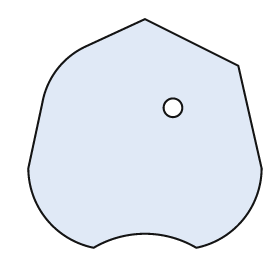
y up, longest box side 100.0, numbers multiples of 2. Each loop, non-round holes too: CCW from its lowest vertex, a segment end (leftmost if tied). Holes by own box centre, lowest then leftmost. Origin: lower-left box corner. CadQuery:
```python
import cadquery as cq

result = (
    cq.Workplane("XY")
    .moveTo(28.0, 0.0)
    .threePointArc((50.0, 6.0), (72.0, 0.0))
    .threePointArc((92.0, 12.0), (100.0, 34.0))
    .lineTo(90.0, 78.0)
    .lineTo(50.0, 98.0)
    .lineTo(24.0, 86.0)
    .threePointArc((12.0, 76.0), (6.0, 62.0))
    .lineTo(0.0, 34.0)
    .threePointArc((8.0, 12.0), (28.0, 0.0))
    .close()
    .moveTo(62.0, 60.0)
    .circle(4.0)
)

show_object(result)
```